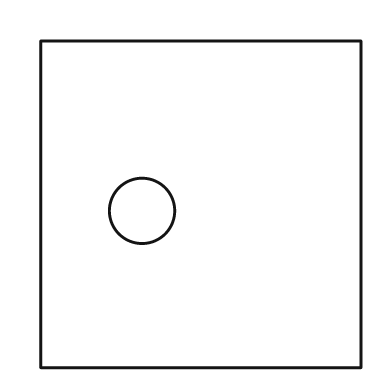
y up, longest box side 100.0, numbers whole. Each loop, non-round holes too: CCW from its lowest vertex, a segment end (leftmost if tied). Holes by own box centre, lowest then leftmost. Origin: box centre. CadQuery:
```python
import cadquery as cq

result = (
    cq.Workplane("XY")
    .moveTo(-49.0, -50.0)
    .lineTo(49.0, -50.0)
    .lineTo(49.0, 50.0)
    .lineTo(-49.0, 50.0)
    .close()
    .moveTo(-18.0, -2.0)
    .circle(10.0)
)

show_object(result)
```